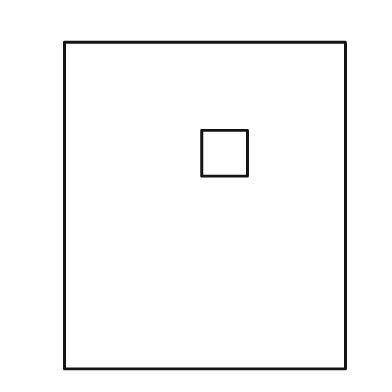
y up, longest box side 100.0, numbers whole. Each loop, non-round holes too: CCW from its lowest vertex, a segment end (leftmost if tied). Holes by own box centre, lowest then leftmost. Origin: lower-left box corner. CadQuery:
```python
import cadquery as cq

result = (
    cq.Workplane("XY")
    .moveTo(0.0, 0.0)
    .lineTo(86.0, 0.0)
    .lineTo(86.0, 100.0)
    .lineTo(0.0, 100.0)
    .close()
    .moveTo(42.0, 59.0)
    .lineTo(56.0, 59.0)
    .lineTo(56.0, 73.0)
    .lineTo(42.0, 73.0)
    .close()
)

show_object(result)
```